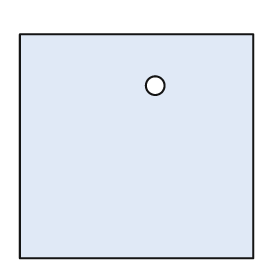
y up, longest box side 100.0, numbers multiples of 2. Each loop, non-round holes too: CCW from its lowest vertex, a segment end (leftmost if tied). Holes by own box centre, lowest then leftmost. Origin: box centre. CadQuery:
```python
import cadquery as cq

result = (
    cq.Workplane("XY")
    .moveTo(-50.0, -48.0)
    .lineTo(50.0, -48.0)
    .lineTo(50.0, 48.0)
    .lineTo(-50.0, 48.0)
    .close()
    .moveTo(8.0, 26.0)
    .circle(4.0)
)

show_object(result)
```